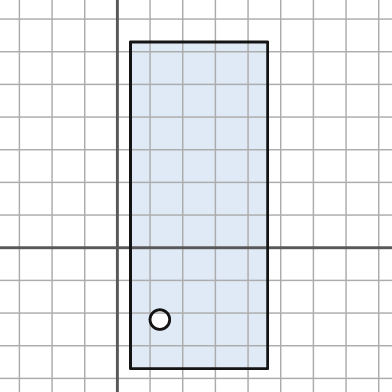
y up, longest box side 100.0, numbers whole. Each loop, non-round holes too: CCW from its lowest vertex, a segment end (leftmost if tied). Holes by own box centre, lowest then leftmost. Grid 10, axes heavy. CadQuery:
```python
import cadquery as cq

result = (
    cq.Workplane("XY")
    .moveTo(4.0, -37.0)
    .lineTo(46.0, -37.0)
    .lineTo(46.0, 63.0)
    .lineTo(4.0, 63.0)
    .close()
    .moveTo(13.0, -22.0)
    .circle(3.0)
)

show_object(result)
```